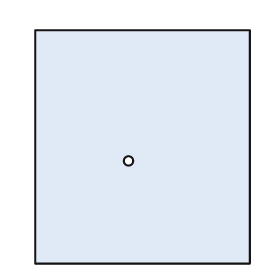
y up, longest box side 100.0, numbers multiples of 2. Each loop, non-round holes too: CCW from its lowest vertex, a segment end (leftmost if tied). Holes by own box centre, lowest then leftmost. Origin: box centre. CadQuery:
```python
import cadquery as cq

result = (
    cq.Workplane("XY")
    .moveTo(-46.0, -50.0)
    .lineTo(46.0, -50.0)
    .lineTo(46.0, 50.0)
    .lineTo(-46.0, 50.0)
    .close()
    .moveTo(-6.0, -6.0)
    .circle(2.0)
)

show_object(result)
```